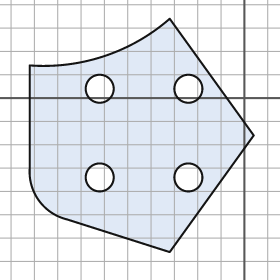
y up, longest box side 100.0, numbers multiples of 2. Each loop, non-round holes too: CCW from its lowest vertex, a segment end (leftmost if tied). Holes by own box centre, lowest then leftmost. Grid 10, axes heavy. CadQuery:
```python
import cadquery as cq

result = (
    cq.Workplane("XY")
    .moveTo(-32.0, -66.0)
    .lineTo(4.0, -16.0)
    .lineTo(-32.0, 34.0)
    .threePointArc((-60.0, 18.0), (-92.0, 14.0))
    .lineTo(-92.0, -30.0)
    .threePointArc((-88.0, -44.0), (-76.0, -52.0))
    .close()
    .moveTo(-62.0, -34.0)
    .circle(6.0)
    .moveTo(-24.0, -34.0)
    .circle(6.0)
    .moveTo(-62.0, 4.0)
    .circle(6.0)
    .moveTo(-24.0, 4.0)
    .circle(6.0)
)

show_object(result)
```